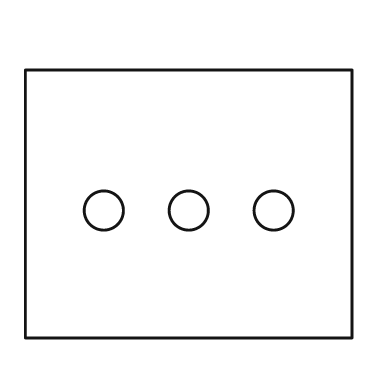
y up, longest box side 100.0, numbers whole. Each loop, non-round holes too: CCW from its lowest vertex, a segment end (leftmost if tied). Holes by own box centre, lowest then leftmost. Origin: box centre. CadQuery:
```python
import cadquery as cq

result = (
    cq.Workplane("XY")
    .moveTo(-50.0, -41.0)
    .lineTo(50.0, -41.0)
    .lineTo(50.0, 41.0)
    .lineTo(-50.0, 41.0)
    .close()
    .moveTo(-26.0, -2.0)
    .circle(6.0)
    .moveTo(0.0, -2.0)
    .circle(6.0)
    .moveTo(26.0, -2.0)
    .circle(6.0)
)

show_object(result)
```